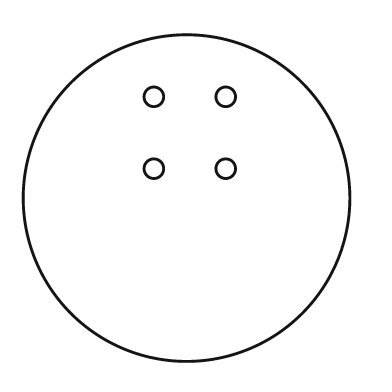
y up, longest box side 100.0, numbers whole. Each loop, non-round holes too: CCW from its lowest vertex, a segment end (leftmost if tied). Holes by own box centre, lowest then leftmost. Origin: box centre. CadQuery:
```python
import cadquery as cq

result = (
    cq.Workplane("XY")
    .moveTo(0.0, 0.0)
    .circle(50.0)
    .moveTo(-10.0, 9.0)
    .circle(3.0)
    .moveTo(12.0, 9.0)
    .circle(3.0)
    .moveTo(-10.0, 31.0)
    .circle(3.0)
    .moveTo(12.0, 31.0)
    .circle(3.0)
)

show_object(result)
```